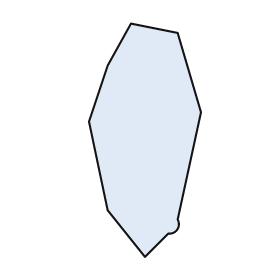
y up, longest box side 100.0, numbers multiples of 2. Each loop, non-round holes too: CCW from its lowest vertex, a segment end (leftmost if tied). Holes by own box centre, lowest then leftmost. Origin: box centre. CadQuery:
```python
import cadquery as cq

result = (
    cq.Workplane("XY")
    .moveTo(0.0, -50.0)
    .lineTo(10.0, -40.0)
    .threePointArc((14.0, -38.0), (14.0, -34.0))
    .lineTo(24.0, 12.0)
    .lineTo(14.0, 46.0)
    .lineTo(-6.0, 50.0)
    .lineTo(-16.0, 32.0)
    .lineTo(-24.0, 8.0)
    .lineTo(-16.0, -30.0)
    .close()
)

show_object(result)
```